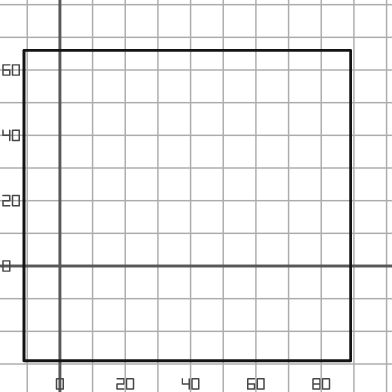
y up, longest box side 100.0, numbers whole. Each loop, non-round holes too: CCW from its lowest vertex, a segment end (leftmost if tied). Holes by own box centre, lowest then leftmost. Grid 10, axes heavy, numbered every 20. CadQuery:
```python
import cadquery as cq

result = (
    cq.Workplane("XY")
    .moveTo(-11.0, -29.0)
    .lineTo(89.0, -29.0)
    .lineTo(89.0, 66.0)
    .lineTo(-11.0, 66.0)
    .close()
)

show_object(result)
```